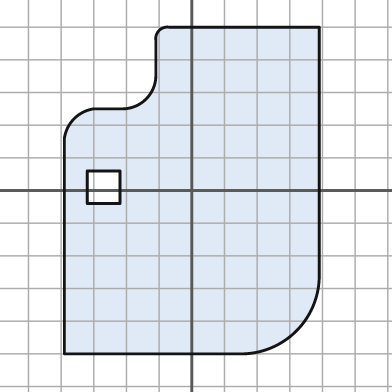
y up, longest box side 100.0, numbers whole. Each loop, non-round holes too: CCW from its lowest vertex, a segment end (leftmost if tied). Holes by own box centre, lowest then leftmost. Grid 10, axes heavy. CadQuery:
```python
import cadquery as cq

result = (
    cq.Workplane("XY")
    .moveTo(-39.0, -50.0)
    .lineTo(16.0, -50.0)
    .threePointArc((32.0, -43.0), (39.0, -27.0))
    .lineTo(39.0, 50.0)
    .lineTo(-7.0, 50.0)
    .threePointArc((-10.0, 49.0), (-11.0, 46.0))
    .lineTo(-11.0, 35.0)
    .threePointArc((-14.0, 28.0), (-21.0, 25.0))
    .lineTo(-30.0, 25.0)
    .threePointArc((-36.0, 22.0), (-39.0, 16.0))
    .close()
    .moveTo(-32.0, -4.0)
    .lineTo(-22.0, -4.0)
    .lineTo(-22.0, 6.0)
    .lineTo(-32.0, 6.0)
    .close()
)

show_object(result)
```